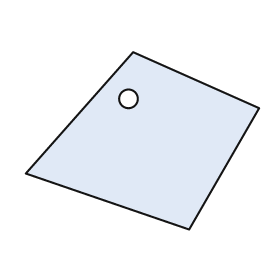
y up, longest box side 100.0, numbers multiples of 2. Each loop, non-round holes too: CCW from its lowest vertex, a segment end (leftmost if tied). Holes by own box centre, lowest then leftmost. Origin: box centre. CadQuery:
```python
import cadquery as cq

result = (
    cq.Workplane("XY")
    .moveTo(20.0, -38.0)
    .lineTo(50.0, 14.0)
    .lineTo(-4.0, 38.0)
    .lineTo(-50.0, -14.0)
    .close()
    .moveTo(-6.0, 18.0)
    .circle(4.0)
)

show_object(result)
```